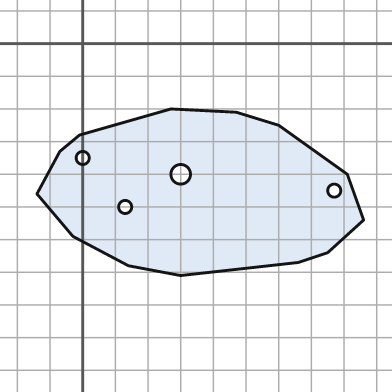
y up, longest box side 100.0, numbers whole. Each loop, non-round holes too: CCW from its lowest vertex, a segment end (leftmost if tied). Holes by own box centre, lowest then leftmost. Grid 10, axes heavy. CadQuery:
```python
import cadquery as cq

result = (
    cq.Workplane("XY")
    .moveTo(30.0, -71.0)
    .lineTo(66.0, -67.0)
    .lineTo(75.0, -64.0)
    .lineTo(86.0, -54.0)
    .lineTo(81.0, -40.0)
    .lineTo(60.0, -25.0)
    .lineTo(47.0, -21.0)
    .lineTo(27.0, -20.0)
    .lineTo(-1.0, -28.0)
    .lineTo(-7.0, -33.0)
    .lineTo(-14.0, -46.0)
    .lineTo(-3.0, -59.0)
    .lineTo(14.0, -68.0)
    .close()
    .moveTo(13.0, -50.0)
    .circle(2.0)
    .moveTo(77.0, -45.0)
    .circle(2.0)
    .moveTo(30.0, -40.0)
    .circle(3.0)
    .moveTo(0.0, -35.0)
    .circle(2.0)
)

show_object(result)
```